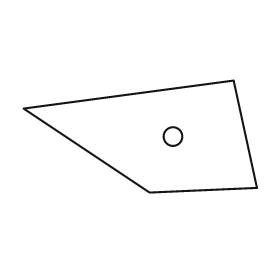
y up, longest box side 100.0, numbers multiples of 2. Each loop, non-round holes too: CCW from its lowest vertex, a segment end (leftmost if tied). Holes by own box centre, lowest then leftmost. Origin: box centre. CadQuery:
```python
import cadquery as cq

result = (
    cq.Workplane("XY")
    .moveTo(4.0, -24.0)
    .lineTo(50.0, -22.0)
    .lineTo(40.0, 24.0)
    .lineTo(-50.0, 12.0)
    .close()
    .moveTo(14.0, 0.0)
    .circle(4.0)
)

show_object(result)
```